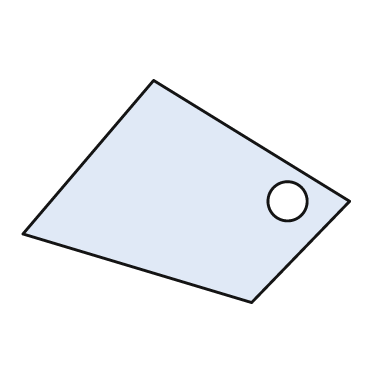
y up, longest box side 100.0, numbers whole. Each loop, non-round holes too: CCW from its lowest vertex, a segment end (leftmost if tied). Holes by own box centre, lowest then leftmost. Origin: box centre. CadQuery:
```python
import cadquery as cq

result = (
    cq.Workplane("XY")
    .moveTo(20.0, -34.0)
    .lineTo(50.0, -3.0)
    .lineTo(-10.0, 34.0)
    .lineTo(-50.0, -13.0)
    .close()
    .moveTo(31.0, -3.0)
    .circle(6.0)
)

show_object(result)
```